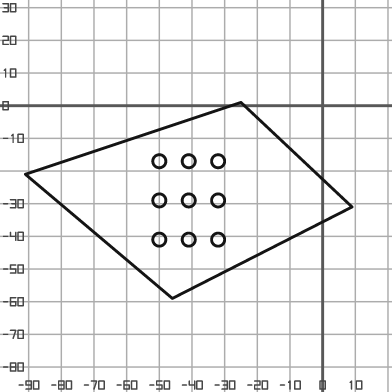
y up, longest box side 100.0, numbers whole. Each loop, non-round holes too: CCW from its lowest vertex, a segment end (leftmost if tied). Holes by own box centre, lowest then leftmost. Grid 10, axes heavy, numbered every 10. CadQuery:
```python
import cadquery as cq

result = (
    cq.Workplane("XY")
    .moveTo(-46.0, -59.0)
    .lineTo(9.0, -31.0)
    .lineTo(-25.0, 1.0)
    .lineTo(-91.0, -21.0)
    .close()
    .moveTo(-50.0, -41.0)
    .circle(2.0)
    .moveTo(-41.0, -41.0)
    .circle(2.0)
    .moveTo(-32.0, -41.0)
    .circle(2.0)
    .moveTo(-50.0, -29.0)
    .circle(2.0)
    .moveTo(-41.0, -29.0)
    .circle(2.0)
    .moveTo(-32.0, -29.0)
    .circle(2.0)
    .moveTo(-50.0, -17.0)
    .circle(2.0)
    .moveTo(-41.0, -17.0)
    .circle(2.0)
    .moveTo(-32.0, -17.0)
    .circle(2.0)
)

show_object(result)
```